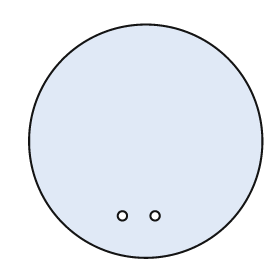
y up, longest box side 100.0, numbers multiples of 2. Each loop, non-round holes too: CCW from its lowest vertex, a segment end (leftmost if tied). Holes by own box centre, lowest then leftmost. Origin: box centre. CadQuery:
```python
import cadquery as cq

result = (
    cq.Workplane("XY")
    .moveTo(0.0, 0.0)
    .circle(50.0)
    .moveTo(-10.0, -32.0)
    .circle(2.0)
    .moveTo(4.0, -32.0)
    .circle(2.0)
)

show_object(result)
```